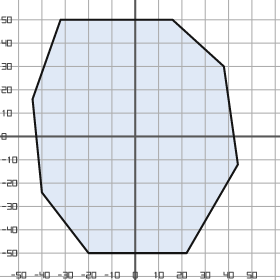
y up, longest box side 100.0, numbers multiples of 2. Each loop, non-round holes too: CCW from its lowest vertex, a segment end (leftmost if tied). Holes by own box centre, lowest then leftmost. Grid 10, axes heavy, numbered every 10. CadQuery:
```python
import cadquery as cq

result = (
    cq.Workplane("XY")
    .moveTo(-20.0, -50.0)
    .lineTo(22.0, -50.0)
    .lineTo(44.0, -12.0)
    .lineTo(38.0, 30.0)
    .lineTo(16.0, 50.0)
    .lineTo(-32.0, 50.0)
    .lineTo(-44.0, 16.0)
    .lineTo(-40.0, -24.0)
    .close()
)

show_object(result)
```